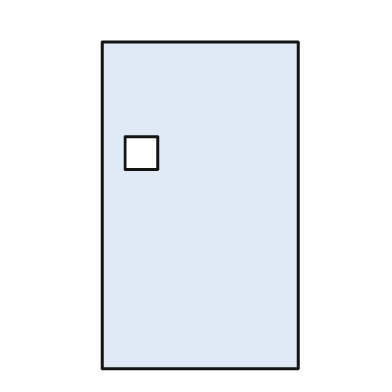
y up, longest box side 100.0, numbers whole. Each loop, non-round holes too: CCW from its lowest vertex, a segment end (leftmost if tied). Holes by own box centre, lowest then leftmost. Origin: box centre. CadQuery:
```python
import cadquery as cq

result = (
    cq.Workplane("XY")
    .moveTo(-30.0, -50.0)
    .lineTo(30.0, -50.0)
    .lineTo(30.0, 50.0)
    .lineTo(-30.0, 50.0)
    .close()
    .moveTo(-23.0, 11.0)
    .lineTo(-13.0, 11.0)
    .lineTo(-13.0, 21.0)
    .lineTo(-23.0, 21.0)
    .close()
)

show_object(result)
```